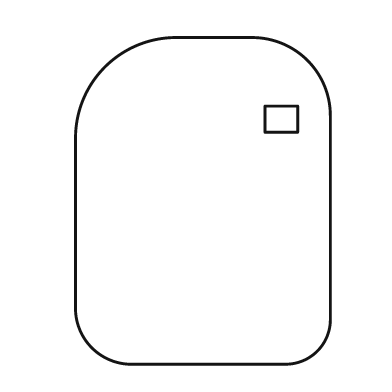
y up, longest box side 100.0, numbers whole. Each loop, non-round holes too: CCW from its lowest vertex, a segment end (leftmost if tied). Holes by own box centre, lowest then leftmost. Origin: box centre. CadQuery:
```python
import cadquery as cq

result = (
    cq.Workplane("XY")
    .moveTo(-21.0, -50.0)
    .lineTo(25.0, -50.0)
    .threePointArc((35.0, -46.0), (39.0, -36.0))
    .lineTo(39.0, 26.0)
    .threePointArc((32.0, 43.0), (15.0, 50.0))
    .lineTo(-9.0, 50.0)
    .threePointArc((-30.0, 41.0), (-39.0, 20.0))
    .lineTo(-39.0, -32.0)
    .threePointArc((-34.0, -45.0), (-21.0, -50.0))
    .close()
    .moveTo(19.0, 21.0)
    .lineTo(29.0, 21.0)
    .lineTo(29.0, 29.0)
    .lineTo(19.0, 29.0)
    .close()
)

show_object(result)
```